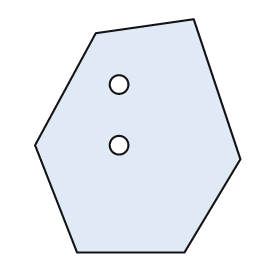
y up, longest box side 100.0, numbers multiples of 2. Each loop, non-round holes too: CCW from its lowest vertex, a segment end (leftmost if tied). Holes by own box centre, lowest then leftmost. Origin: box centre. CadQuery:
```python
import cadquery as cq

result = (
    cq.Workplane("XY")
    .moveTo(-26.0, -50.0)
    .lineTo(20.0, -50.0)
    .lineTo(44.0, -10.0)
    .lineTo(24.0, 50.0)
    .lineTo(-18.0, 44.0)
    .lineTo(-44.0, -4.0)
    .close()
    .moveTo(-8.0, -4.0)
    .circle(4.0)
    .moveTo(-8.0, 22.0)
    .circle(4.0)
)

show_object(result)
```